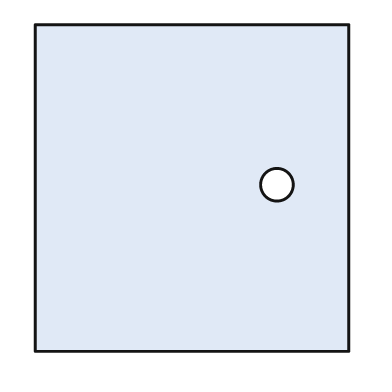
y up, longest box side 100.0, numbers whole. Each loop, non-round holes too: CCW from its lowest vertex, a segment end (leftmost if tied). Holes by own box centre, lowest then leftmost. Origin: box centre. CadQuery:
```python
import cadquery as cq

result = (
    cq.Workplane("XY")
    .moveTo(-48.0, -50.0)
    .lineTo(48.0, -50.0)
    .lineTo(48.0, 50.0)
    .lineTo(-48.0, 50.0)
    .close()
    .moveTo(26.0, 1.0)
    .circle(5.0)
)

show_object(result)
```